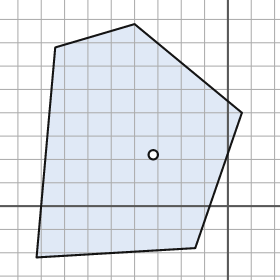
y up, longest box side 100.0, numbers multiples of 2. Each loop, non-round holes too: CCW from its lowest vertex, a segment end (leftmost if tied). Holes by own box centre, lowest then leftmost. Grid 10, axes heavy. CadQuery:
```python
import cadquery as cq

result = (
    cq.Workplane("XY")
    .moveTo(-82.0, -22.0)
    .lineTo(-14.0, -18.0)
    .lineTo(6.0, 40.0)
    .lineTo(-40.0, 78.0)
    .lineTo(-74.0, 68.0)
    .close()
    .moveTo(-32.0, 22.0)
    .circle(2.0)
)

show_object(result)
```